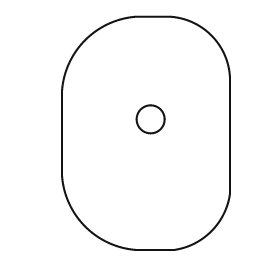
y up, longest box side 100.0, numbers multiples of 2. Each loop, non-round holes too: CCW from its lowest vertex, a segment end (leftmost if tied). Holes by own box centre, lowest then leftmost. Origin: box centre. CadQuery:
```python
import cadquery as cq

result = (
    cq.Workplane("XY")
    .moveTo(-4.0, -50.0)
    .lineTo(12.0, -50.0)
    .threePointArc((28.0, -42.0), (36.0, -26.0))
    .lineTo(36.0, 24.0)
    .threePointArc((28.0, 42.0), (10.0, 50.0))
    .lineTo(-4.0, 50.0)
    .threePointArc((-26.0, 40.0), (-36.0, 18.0))
    .lineTo(-36.0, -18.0)
    .threePointArc((-26.0, -40.0), (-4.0, -50.0))
    .close()
    .moveTo(2.0, 6.0)
    .circle(6.0)
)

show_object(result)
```